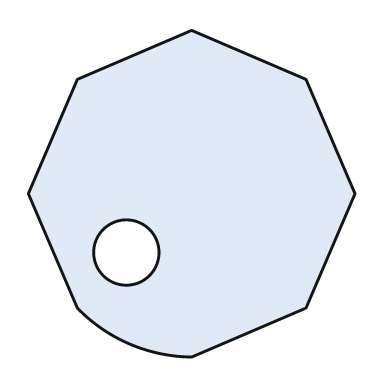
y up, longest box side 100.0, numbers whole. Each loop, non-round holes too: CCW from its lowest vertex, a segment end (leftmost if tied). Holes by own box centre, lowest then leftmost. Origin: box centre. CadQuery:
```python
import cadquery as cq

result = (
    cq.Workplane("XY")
    .moveTo(0.0, -50.0)
    .lineTo(35.0, -35.0)
    .lineTo(50.0, 0.0)
    .lineTo(35.0, 35.0)
    .lineTo(0.0, 50.0)
    .lineTo(-35.0, 35.0)
    .lineTo(-50.0, 0.0)
    .lineTo(-35.0, -35.0)
    .threePointArc((-19.0, -46.0), (0.0, -50.0))
    .close()
    .moveTo(-20.0, -18.0)
    .circle(10.0)
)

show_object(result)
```